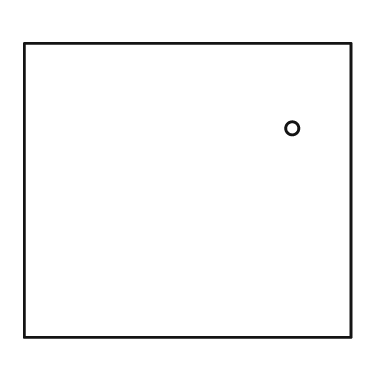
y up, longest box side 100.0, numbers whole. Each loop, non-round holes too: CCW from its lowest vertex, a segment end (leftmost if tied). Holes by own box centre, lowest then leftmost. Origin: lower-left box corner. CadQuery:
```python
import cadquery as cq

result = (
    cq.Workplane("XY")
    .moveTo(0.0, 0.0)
    .lineTo(100.0, 0.0)
    .lineTo(100.0, 90.0)
    .lineTo(0.0, 90.0)
    .close()
    .moveTo(82.0, 64.0)
    .circle(2.0)
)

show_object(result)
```